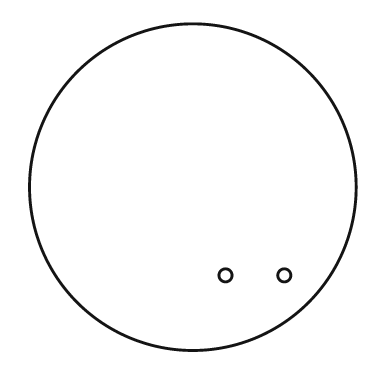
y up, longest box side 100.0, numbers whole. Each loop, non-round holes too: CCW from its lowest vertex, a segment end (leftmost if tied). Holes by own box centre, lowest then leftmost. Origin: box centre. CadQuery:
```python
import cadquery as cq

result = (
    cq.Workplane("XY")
    .moveTo(0.0, 0.0)
    .circle(50.0)
    .moveTo(10.0, -27.0)
    .circle(2.0)
    .moveTo(28.0, -27.0)
    .circle(2.0)
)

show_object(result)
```